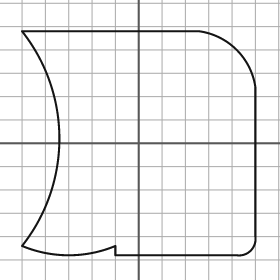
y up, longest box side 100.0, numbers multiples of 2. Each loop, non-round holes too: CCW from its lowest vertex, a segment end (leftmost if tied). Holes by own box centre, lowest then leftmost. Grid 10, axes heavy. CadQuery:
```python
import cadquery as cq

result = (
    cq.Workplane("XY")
    .moveTo(-10.0, -48.0)
    .lineTo(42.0, -48.0)
    .threePointArc((48.0, -46.0), (50.0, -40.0))
    .lineTo(50.0, 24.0)
    .threePointArc((42.0, 40.0), (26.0, 48.0))
    .lineTo(-50.0, 48.0)
    .threePointArc((-34.0, 2.0), (-50.0, -44.0))
    .threePointArc((-30.0, -48.0), (-10.0, -44.0))
    .close()
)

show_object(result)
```